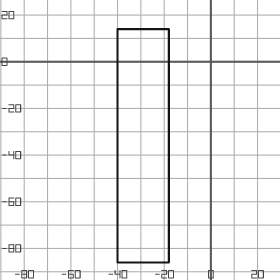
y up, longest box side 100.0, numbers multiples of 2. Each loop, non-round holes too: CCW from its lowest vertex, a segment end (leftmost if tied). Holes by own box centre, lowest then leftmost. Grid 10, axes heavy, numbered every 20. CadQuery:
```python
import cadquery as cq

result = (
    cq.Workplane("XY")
    .moveTo(-40.0, -86.0)
    .lineTo(-18.0, -86.0)
    .lineTo(-18.0, 14.0)
    .lineTo(-40.0, 14.0)
    .close()
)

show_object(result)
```